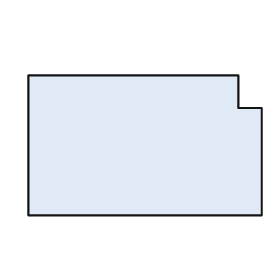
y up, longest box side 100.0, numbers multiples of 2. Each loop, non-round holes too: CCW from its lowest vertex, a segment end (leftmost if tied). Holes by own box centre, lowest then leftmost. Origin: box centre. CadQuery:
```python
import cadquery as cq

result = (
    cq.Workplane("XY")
    .moveTo(-50.0, -30.0)
    .lineTo(50.0, -30.0)
    .lineTo(50.0, 16.0)
    .lineTo(40.0, 16.0)
    .lineTo(40.0, 30.0)
    .lineTo(-50.0, 30.0)
    .close()
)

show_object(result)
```